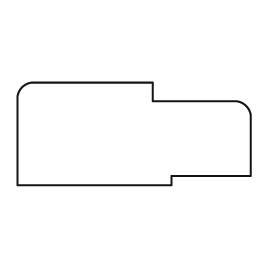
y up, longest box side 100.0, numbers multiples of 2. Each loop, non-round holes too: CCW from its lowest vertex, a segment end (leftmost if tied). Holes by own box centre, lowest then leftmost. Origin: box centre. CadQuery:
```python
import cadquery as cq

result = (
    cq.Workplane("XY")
    .moveTo(-50.0, -22.0)
    .lineTo(16.0, -22.0)
    .lineTo(16.0, -18.0)
    .lineTo(50.0, -18.0)
    .lineTo(50.0, 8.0)
    .threePointArc((48.0, 12.0), (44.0, 14.0))
    .lineTo(8.0, 14.0)
    .lineTo(8.0, 22.0)
    .lineTo(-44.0, 22.0)
    .threePointArc((-48.0, 20.0), (-50.0, 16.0))
    .close()
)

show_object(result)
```